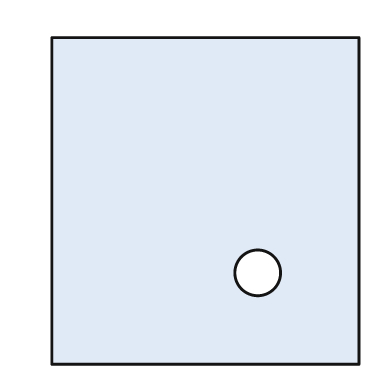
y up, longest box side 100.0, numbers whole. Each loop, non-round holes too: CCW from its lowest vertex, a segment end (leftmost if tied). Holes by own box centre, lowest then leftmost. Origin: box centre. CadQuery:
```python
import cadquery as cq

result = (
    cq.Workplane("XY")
    .moveTo(-47.0, -50.0)
    .lineTo(47.0, -50.0)
    .lineTo(47.0, 50.0)
    .lineTo(-47.0, 50.0)
    .close()
    .moveTo(16.0, -22.0)
    .circle(7.0)
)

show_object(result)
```